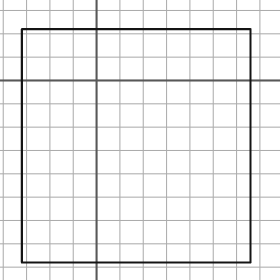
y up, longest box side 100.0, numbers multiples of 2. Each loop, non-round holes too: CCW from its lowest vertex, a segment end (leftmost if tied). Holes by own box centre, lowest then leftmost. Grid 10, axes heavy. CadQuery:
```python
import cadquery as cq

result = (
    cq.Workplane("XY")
    .moveTo(-32.0, -78.0)
    .lineTo(66.0, -78.0)
    .lineTo(66.0, 22.0)
    .lineTo(-32.0, 22.0)
    .close()
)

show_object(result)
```